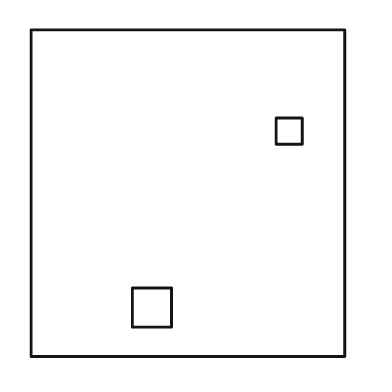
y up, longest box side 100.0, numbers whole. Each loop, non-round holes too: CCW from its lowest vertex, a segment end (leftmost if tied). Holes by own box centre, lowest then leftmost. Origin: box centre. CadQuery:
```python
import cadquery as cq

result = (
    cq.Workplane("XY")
    .moveTo(-48.0, -50.0)
    .lineTo(48.0, -50.0)
    .lineTo(48.0, 50.0)
    .lineTo(-48.0, 50.0)
    .close()
    .moveTo(-17.0, -41.0)
    .lineTo(-5.0, -41.0)
    .lineTo(-5.0, -29.0)
    .lineTo(-17.0, -29.0)
    .close()
    .moveTo(27.0, 15.0)
    .lineTo(35.0, 15.0)
    .lineTo(35.0, 23.0)
    .lineTo(27.0, 23.0)
    .close()
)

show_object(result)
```